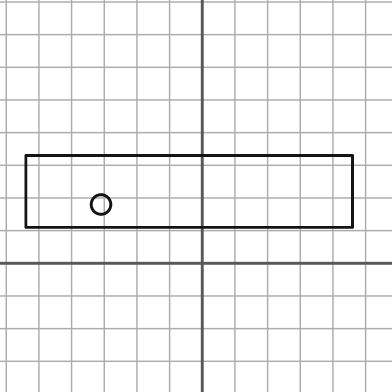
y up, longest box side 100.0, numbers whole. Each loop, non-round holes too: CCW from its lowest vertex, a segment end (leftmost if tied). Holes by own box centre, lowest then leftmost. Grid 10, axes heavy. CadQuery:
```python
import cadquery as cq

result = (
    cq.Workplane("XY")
    .moveTo(-54.0, 11.0)
    .lineTo(46.0, 11.0)
    .lineTo(46.0, 33.0)
    .lineTo(-54.0, 33.0)
    .close()
    .moveTo(-31.0, 18.0)
    .circle(3.0)
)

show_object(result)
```